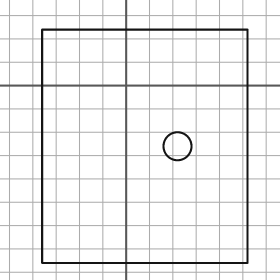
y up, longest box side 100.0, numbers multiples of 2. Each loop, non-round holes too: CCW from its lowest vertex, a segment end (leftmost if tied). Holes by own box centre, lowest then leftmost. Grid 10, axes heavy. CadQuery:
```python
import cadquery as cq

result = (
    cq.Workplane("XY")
    .moveTo(-36.0, -76.0)
    .lineTo(52.0, -76.0)
    .lineTo(52.0, 24.0)
    .lineTo(-36.0, 24.0)
    .close()
    .moveTo(22.0, -26.0)
    .circle(6.0)
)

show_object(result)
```